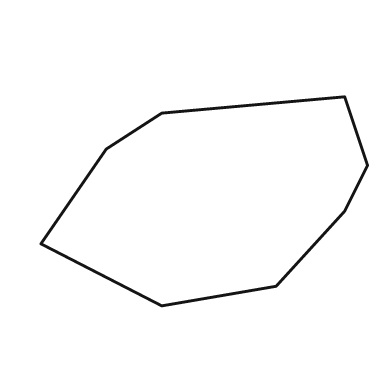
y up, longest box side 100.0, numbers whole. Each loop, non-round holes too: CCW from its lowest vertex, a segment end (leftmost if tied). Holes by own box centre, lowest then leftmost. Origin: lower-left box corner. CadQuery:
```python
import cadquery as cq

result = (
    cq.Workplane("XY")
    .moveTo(37.0, 0.0)
    .lineTo(72.0, 6.0)
    .lineTo(93.0, 29.0)
    .lineTo(100.0, 43.0)
    .lineTo(93.0, 64.0)
    .lineTo(37.0, 59.0)
    .lineTo(20.0, 48.0)
    .lineTo(0.0, 19.0)
    .close()
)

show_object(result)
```